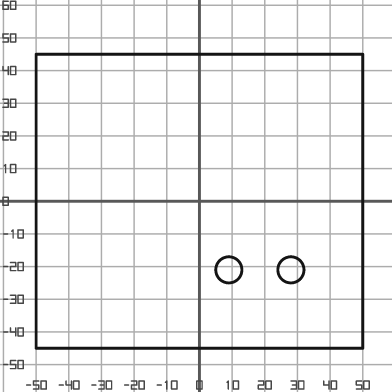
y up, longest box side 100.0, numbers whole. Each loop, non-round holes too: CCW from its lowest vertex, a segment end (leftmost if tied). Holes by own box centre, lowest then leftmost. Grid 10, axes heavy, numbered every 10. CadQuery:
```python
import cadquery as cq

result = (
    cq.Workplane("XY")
    .moveTo(-50.0, -45.0)
    .lineTo(50.0, -45.0)
    .lineTo(50.0, 45.0)
    .lineTo(-50.0, 45.0)
    .close()
    .moveTo(9.0, -21.0)
    .circle(4.0)
    .moveTo(28.0, -21.0)
    .circle(4.0)
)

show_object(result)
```